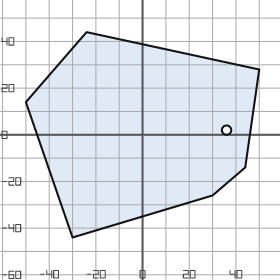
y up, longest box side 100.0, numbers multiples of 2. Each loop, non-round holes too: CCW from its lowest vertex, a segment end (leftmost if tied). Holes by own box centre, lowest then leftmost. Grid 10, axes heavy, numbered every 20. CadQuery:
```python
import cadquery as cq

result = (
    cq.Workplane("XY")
    .moveTo(-30.0, -44.0)
    .lineTo(30.0, -26.0)
    .lineTo(44.0, -14.0)
    .lineTo(50.0, 28.0)
    .lineTo(-24.0, 44.0)
    .lineTo(-50.0, 14.0)
    .close()
    .moveTo(36.0, 2.0)
    .circle(2.0)
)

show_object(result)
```